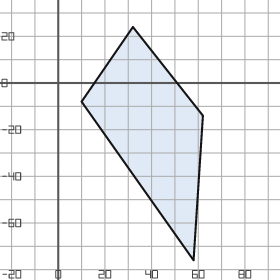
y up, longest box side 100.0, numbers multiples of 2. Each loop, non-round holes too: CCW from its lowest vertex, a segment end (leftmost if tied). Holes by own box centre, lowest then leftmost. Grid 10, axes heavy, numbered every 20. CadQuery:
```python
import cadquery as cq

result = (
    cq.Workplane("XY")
    .moveTo(58.0, -76.0)
    .lineTo(62.0, -14.0)
    .lineTo(32.0, 24.0)
    .lineTo(10.0, -8.0)
    .close()
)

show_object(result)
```